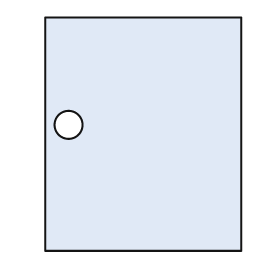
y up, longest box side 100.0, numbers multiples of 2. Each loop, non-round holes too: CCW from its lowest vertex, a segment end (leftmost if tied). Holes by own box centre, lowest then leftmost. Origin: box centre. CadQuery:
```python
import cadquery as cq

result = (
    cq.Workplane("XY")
    .moveTo(-42.0, -50.0)
    .lineTo(42.0, -50.0)
    .lineTo(42.0, 50.0)
    .lineTo(-42.0, 50.0)
    .close()
    .moveTo(-32.0, 4.0)
    .circle(6.0)
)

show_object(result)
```